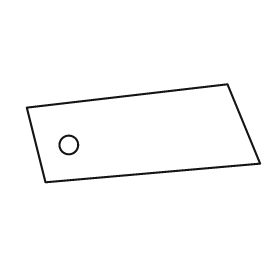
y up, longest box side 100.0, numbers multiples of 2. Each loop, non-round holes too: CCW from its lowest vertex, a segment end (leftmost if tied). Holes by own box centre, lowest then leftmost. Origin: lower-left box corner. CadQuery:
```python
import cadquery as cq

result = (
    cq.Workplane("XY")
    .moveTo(8.0, 0.0)
    .lineTo(100.0, 8.0)
    .lineTo(86.0, 42.0)
    .lineTo(0.0, 32.0)
    .close()
    .moveTo(18.0, 16.0)
    .circle(4.0)
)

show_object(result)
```